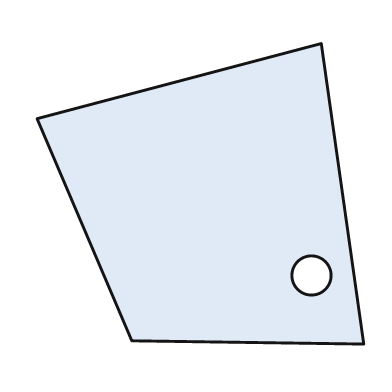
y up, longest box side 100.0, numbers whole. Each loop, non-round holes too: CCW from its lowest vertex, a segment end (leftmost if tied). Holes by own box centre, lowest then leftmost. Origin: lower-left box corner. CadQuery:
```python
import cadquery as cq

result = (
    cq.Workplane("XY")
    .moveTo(100.0, 0.0)
    .lineTo(87.0, 92.0)
    .lineTo(0.0, 69.0)
    .lineTo(29.0, 1.0)
    .close()
    .moveTo(84.0, 21.0)
    .circle(6.0)
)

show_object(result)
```